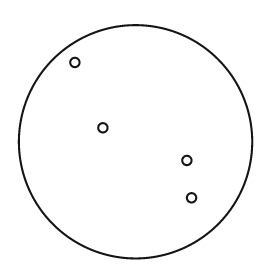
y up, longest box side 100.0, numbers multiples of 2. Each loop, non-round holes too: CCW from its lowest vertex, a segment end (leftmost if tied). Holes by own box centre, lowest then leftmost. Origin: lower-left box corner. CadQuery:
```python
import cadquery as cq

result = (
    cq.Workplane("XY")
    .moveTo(50.0, 50.0)
    .circle(50.0)
    .moveTo(74.0, 26.0)
    .circle(2.0)
    .moveTo(72.0, 42.0)
    .circle(2.0)
    .moveTo(36.0, 56.0)
    .circle(2.0)
    .moveTo(24.0, 84.0)
    .circle(2.0)
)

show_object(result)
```